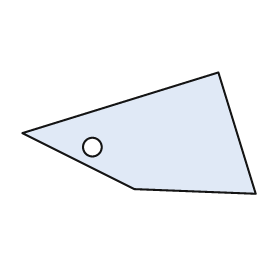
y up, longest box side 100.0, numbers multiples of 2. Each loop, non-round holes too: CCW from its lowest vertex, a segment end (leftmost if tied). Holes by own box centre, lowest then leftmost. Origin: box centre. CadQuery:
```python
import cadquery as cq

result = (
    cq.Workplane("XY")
    .moveTo(50.0, -26.0)
    .lineTo(34.0, 26.0)
    .lineTo(-50.0, 0.0)
    .lineTo(-2.0, -24.0)
    .close()
    .moveTo(-20.0, -6.0)
    .circle(4.0)
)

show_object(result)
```